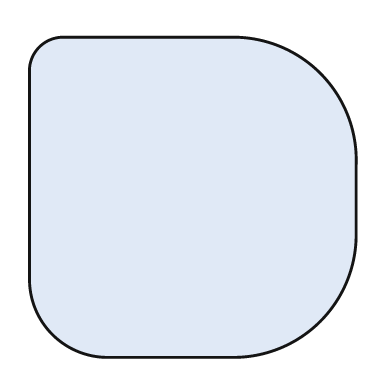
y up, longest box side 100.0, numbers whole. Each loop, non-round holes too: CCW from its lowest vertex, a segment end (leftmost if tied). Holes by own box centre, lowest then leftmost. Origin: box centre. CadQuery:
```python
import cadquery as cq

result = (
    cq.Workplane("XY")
    .moveTo(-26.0, -49.0)
    .lineTo(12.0, -49.0)
    .threePointArc((39.0, -38.0), (50.0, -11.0))
    .lineTo(50.0, 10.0)
    .threePointArc((39.0, 38.0), (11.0, 49.0))
    .lineTo(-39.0, 49.0)
    .threePointArc((-47.0, 46.0), (-50.0, 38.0))
    .lineTo(-50.0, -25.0)
    .threePointArc((-43.0, -42.0), (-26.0, -49.0))
    .close()
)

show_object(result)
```